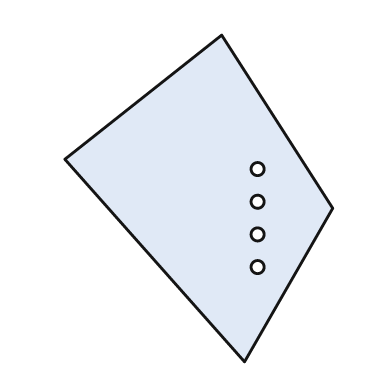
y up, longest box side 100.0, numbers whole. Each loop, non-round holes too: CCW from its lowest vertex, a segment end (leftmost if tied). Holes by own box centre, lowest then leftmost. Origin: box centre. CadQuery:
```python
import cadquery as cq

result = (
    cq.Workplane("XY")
    .moveTo(14.0, -50.0)
    .lineTo(41.0, -3.0)
    .lineTo(7.0, 50.0)
    .lineTo(-41.0, 12.0)
    .close()
    .moveTo(18.0, -21.0)
    .circle(2.0)
    .moveTo(18.0, -11.0)
    .circle(2.0)
    .moveTo(18.0, -1.0)
    .circle(2.0)
    .moveTo(18.0, 9.0)
    .circle(2.0)
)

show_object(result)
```